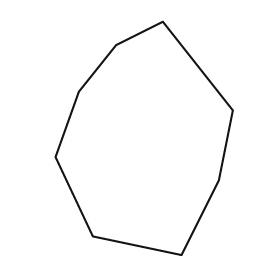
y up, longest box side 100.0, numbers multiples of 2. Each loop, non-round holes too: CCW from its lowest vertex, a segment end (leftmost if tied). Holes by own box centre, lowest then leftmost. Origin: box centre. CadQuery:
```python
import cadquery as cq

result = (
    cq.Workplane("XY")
    .moveTo(16.0, -50.0)
    .lineTo(32.0, -18.0)
    .lineTo(38.0, 12.0)
    .lineTo(8.0, 50.0)
    .lineTo(-12.0, 40.0)
    .lineTo(-28.0, 20.0)
    .lineTo(-38.0, -8.0)
    .lineTo(-22.0, -42.0)
    .close()
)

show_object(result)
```